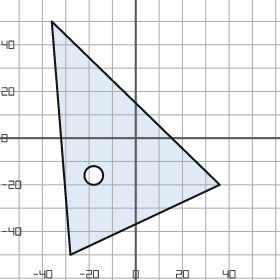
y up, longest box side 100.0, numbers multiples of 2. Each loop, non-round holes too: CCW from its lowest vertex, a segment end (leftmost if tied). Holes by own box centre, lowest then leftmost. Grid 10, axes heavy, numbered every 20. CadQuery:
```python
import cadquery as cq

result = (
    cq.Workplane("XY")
    .moveTo(-28.0, -50.0)
    .lineTo(36.0, -20.0)
    .lineTo(-36.0, 50.0)
    .close()
    .moveTo(-18.0, -16.0)
    .circle(4.0)
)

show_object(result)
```